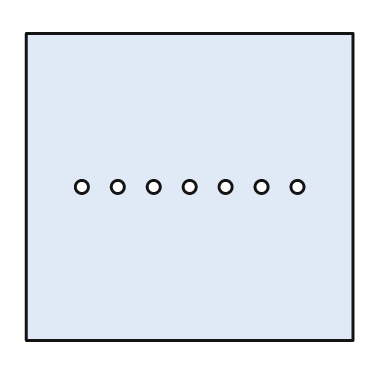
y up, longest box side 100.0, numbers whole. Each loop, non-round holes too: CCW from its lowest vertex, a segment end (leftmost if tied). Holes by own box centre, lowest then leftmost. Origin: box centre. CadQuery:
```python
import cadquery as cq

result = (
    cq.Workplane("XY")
    .moveTo(-50.0, -47.0)
    .lineTo(50.0, -47.0)
    .lineTo(50.0, 47.0)
    .lineTo(-50.0, 47.0)
    .close()
    .moveTo(-33.0, 0.0)
    .circle(2.0)
    .moveTo(-22.0, 0.0)
    .circle(2.0)
    .moveTo(-11.0, 0.0)
    .circle(2.0)
    .moveTo(0.0, 0.0)
    .circle(2.0)
    .moveTo(11.0, 0.0)
    .circle(2.0)
    .moveTo(22.0, 0.0)
    .circle(2.0)
    .moveTo(33.0, 0.0)
    .circle(2.0)
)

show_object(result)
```